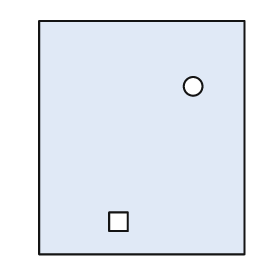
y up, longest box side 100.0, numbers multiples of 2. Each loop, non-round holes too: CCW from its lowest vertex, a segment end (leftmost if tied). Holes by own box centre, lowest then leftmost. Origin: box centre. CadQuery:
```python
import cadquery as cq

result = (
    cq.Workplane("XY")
    .moveTo(-44.0, -50.0)
    .lineTo(44.0, -50.0)
    .lineTo(44.0, 50.0)
    .lineTo(-44.0, 50.0)
    .close()
    .moveTo(-14.0, -40.0)
    .lineTo(-6.0, -40.0)
    .lineTo(-6.0, -32.0)
    .lineTo(-14.0, -32.0)
    .close()
    .moveTo(22.0, 22.0)
    .circle(4.0)
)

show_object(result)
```